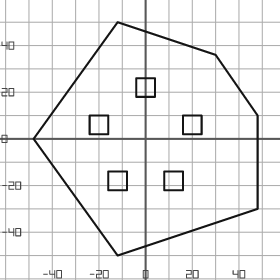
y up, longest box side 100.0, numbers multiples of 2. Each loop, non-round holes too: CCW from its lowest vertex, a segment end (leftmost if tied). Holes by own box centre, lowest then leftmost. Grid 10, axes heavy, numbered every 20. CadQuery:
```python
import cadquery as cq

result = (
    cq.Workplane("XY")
    .moveTo(-12.0, -50.0)
    .lineTo(48.0, -30.0)
    .lineTo(48.0, 10.0)
    .lineTo(30.0, 36.0)
    .lineTo(-12.0, 50.0)
    .lineTo(-48.0, 0.0)
    .close()
    .moveTo(-16.0, -22.0)
    .lineTo(-8.0, -22.0)
    .lineTo(-8.0, -14.0)
    .lineTo(-16.0, -14.0)
    .close()
    .moveTo(8.0, -22.0)
    .lineTo(16.0, -22.0)
    .lineTo(16.0, -14.0)
    .lineTo(8.0, -14.0)
    .close()
    .moveTo(-24.0, 2.0)
    .lineTo(-16.0, 2.0)
    .lineTo(-16.0, 10.0)
    .lineTo(-24.0, 10.0)
    .close()
    .moveTo(16.0, 2.0)
    .lineTo(24.0, 2.0)
    .lineTo(24.0, 10.0)
    .lineTo(16.0, 10.0)
    .close()
    .moveTo(-4.0, 18.0)
    .lineTo(4.0, 18.0)
    .lineTo(4.0, 26.0)
    .lineTo(-4.0, 26.0)
    .close()
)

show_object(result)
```